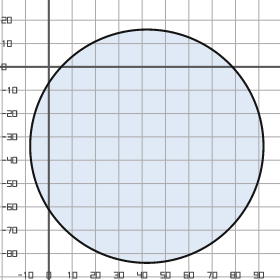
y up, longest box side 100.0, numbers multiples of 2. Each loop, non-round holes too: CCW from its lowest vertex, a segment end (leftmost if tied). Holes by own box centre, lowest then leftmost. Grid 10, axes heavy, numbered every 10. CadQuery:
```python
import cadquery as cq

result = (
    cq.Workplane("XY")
    .moveTo(42.0, -34.0)
    .circle(50.0)
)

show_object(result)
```